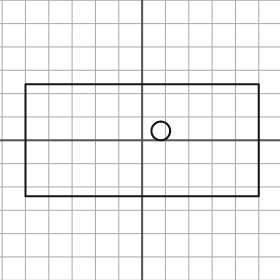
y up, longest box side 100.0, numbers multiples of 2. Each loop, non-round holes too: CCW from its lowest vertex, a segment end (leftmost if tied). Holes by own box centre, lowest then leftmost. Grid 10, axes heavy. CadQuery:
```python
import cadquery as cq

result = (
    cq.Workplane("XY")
    .moveTo(-50.0, -24.0)
    .lineTo(50.0, -24.0)
    .lineTo(50.0, 24.0)
    .lineTo(-50.0, 24.0)
    .close()
    .moveTo(8.0, 4.0)
    .circle(4.0)
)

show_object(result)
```